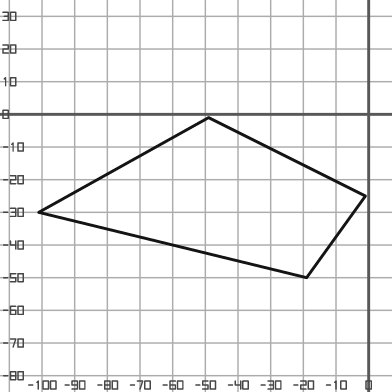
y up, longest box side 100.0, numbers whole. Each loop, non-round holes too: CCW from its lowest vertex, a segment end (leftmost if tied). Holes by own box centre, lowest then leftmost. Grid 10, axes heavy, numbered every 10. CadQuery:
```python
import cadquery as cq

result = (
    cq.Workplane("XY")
    .moveTo(-19.0, -50.0)
    .lineTo(-1.0, -25.0)
    .lineTo(-49.0, -1.0)
    .lineTo(-101.0, -30.0)
    .close()
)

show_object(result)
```